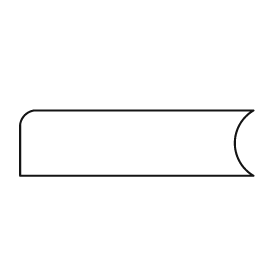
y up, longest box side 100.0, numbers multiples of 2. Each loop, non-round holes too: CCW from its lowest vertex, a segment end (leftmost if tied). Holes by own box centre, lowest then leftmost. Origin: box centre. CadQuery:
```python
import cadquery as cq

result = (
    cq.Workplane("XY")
    .moveTo(-50.0, -14.0)
    .lineTo(50.0, -14.0)
    .threePointArc((42.0, 0.0), (50.0, 14.0))
    .lineTo(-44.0, 14.0)
    .threePointArc((-48.0, 12.0), (-50.0, 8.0))
    .close()
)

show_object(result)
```